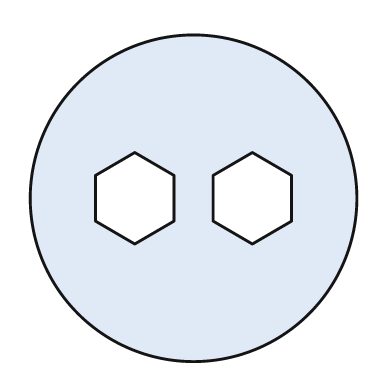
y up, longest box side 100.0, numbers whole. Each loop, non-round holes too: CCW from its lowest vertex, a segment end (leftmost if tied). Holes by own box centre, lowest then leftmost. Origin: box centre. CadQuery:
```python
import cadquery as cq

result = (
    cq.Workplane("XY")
    .moveTo(0.0, 0.0)
    .circle(50.0)
    .moveTo(-18.0, -14.0)
    .lineTo(-6.0, -7.0)
    .lineTo(-6.0, 7.0)
    .lineTo(-18.0, 14.0)
    .lineTo(-30.0, 7.0)
    .lineTo(-30.0, -7.0)
    .close()
    .moveTo(18.0, -14.0)
    .lineTo(30.0, -7.0)
    .lineTo(30.0, 7.0)
    .lineTo(18.0, 14.0)
    .lineTo(6.0, 7.0)
    .lineTo(6.0, -7.0)
    .close()
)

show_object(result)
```